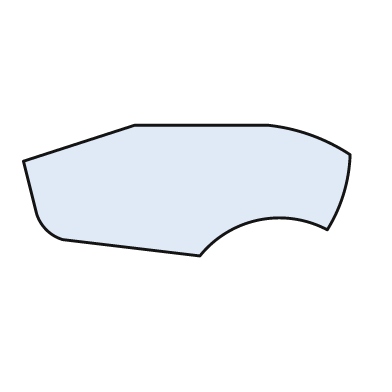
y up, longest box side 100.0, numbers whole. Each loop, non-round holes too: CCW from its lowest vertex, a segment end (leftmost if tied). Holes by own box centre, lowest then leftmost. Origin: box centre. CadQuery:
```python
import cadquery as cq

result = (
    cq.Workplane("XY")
    .moveTo(4.0, -20.0)
    .threePointArc((22.0, -9.0), (43.0, -12.0))
    .threePointArc((48.0, -1.0), (50.0, 11.0))
    .threePointArc((38.0, 17.0), (25.0, 20.0))
    .lineTo(-16.0, 20.0)
    .lineTo(-50.0, 9.0)
    .lineTo(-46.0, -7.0)
    .threePointArc((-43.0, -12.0), (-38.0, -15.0))
    .close()
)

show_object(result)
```